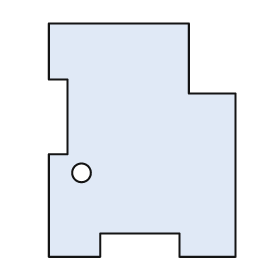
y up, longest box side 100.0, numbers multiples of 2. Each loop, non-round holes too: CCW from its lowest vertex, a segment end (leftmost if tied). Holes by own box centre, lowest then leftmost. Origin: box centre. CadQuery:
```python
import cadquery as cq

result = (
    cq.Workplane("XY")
    .moveTo(-40.0, -50.0)
    .lineTo(-18.0, -50.0)
    .lineTo(-18.0, -40.0)
    .lineTo(16.0, -40.0)
    .lineTo(16.0, -50.0)
    .lineTo(40.0, -50.0)
    .lineTo(40.0, 20.0)
    .lineTo(20.0, 20.0)
    .lineTo(20.0, 50.0)
    .lineTo(-40.0, 50.0)
    .lineTo(-40.0, 26.0)
    .lineTo(-32.0, 26.0)
    .lineTo(-32.0, -6.0)
    .lineTo(-40.0, -6.0)
    .close()
    .moveTo(-26.0, -14.0)
    .circle(4.0)
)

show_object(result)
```